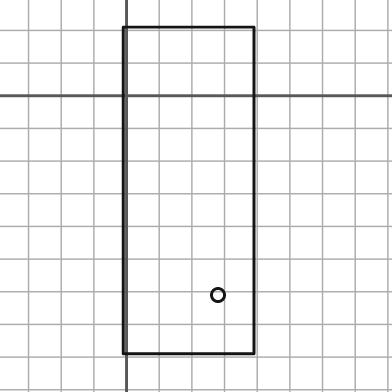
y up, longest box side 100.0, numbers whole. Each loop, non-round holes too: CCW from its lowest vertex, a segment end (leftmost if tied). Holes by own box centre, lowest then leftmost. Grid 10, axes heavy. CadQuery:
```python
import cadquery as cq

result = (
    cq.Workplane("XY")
    .moveTo(-1.0, -79.0)
    .lineTo(39.0, -79.0)
    .lineTo(39.0, 21.0)
    .lineTo(-1.0, 21.0)
    .close()
    .moveTo(28.0, -61.0)
    .circle(2.0)
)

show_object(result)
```